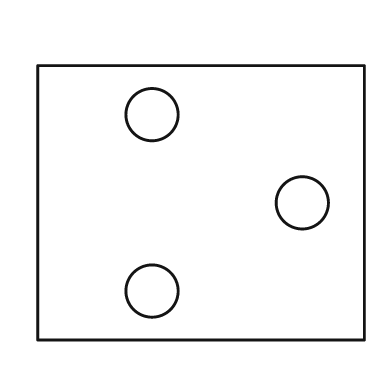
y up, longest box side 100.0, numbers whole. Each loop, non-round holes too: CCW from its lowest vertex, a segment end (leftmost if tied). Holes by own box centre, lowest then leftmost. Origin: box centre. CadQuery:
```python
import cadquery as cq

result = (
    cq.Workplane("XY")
    .moveTo(-50.0, -42.0)
    .lineTo(50.0, -42.0)
    .lineTo(50.0, 42.0)
    .lineTo(-50.0, 42.0)
    .close()
    .moveTo(-15.0, -27.0)
    .circle(8.0)
    .moveTo(31.0, 0.0)
    .circle(8.0)
    .moveTo(-15.0, 27.0)
    .circle(8.0)
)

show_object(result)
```